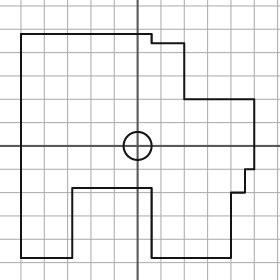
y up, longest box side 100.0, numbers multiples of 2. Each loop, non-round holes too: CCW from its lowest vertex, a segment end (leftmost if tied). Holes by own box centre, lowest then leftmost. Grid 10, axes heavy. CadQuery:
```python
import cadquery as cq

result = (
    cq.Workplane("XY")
    .moveTo(-50.0, -48.0)
    .lineTo(-28.0, -48.0)
    .lineTo(-28.0, -18.0)
    .lineTo(6.0, -18.0)
    .lineTo(6.0, -48.0)
    .lineTo(40.0, -48.0)
    .lineTo(40.0, -20.0)
    .lineTo(46.0, -20.0)
    .lineTo(46.0, -10.0)
    .lineTo(50.0, -10.0)
    .lineTo(50.0, 20.0)
    .lineTo(20.0, 20.0)
    .lineTo(20.0, 44.0)
    .lineTo(6.0, 44.0)
    .lineTo(6.0, 48.0)
    .lineTo(-50.0, 48.0)
    .close()
    .moveTo(0.0, 0.0)
    .circle(6.0)
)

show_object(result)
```